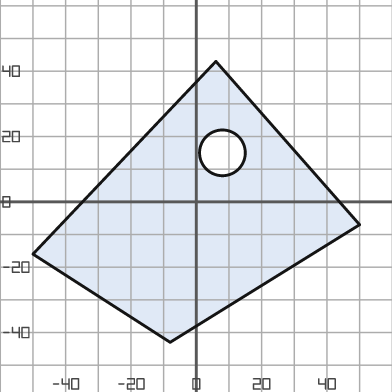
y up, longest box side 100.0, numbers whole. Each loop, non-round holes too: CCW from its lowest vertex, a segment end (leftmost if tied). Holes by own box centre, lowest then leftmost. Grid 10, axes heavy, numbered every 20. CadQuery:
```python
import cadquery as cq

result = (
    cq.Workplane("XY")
    .moveTo(-8.0, -43.0)
    .lineTo(50.0, -7.0)
    .lineTo(6.0, 43.0)
    .lineTo(-50.0, -16.0)
    .close()
    .moveTo(8.0, 15.0)
    .circle(7.0)
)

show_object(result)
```